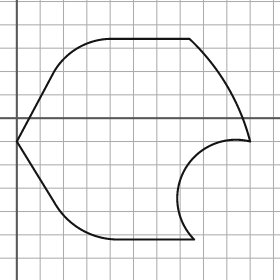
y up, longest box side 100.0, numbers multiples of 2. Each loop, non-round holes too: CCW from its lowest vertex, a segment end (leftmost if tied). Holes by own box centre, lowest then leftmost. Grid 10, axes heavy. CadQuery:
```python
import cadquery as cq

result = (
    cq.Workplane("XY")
    .moveTo(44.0, -52.0)
    .lineTo(76.0, -52.0)
    .threePointArc((72.0, -22.0), (100.0, -10.0))
    .threePointArc((90.0, 14.0), (74.0, 34.0))
    .lineTo(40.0, 34.0)
    .threePointArc((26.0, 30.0), (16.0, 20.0))
    .lineTo(0.0, -10.0)
    .lineTo(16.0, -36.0)
    .threePointArc((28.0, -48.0), (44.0, -52.0))
    .close()
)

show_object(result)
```